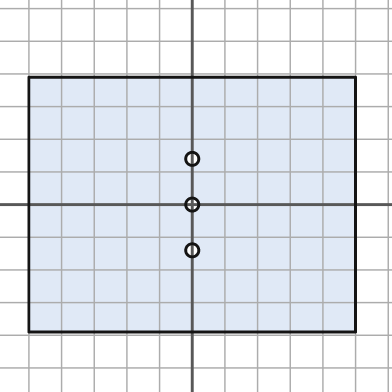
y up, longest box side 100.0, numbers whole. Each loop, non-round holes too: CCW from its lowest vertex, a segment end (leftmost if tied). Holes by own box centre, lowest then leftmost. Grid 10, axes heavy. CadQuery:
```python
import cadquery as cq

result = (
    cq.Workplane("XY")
    .moveTo(-50.0, -39.0)
    .lineTo(50.0, -39.0)
    .lineTo(50.0, 39.0)
    .lineTo(-50.0, 39.0)
    .close()
    .moveTo(0.0, -14.0)
    .circle(2.0)
    .moveTo(0.0, 0.0)
    .circle(2.0)
    .moveTo(0.0, 14.0)
    .circle(2.0)
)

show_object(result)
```